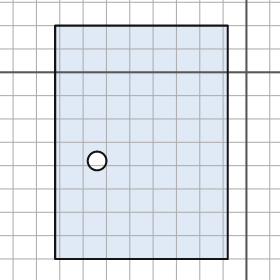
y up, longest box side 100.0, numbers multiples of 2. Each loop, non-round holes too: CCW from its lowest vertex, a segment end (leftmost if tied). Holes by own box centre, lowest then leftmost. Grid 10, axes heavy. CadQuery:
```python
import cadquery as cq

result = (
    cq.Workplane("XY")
    .moveTo(-82.0, -80.0)
    .lineTo(-8.0, -80.0)
    .lineTo(-8.0, 20.0)
    .lineTo(-82.0, 20.0)
    .close()
    .moveTo(-64.0, -38.0)
    .circle(4.0)
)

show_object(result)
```